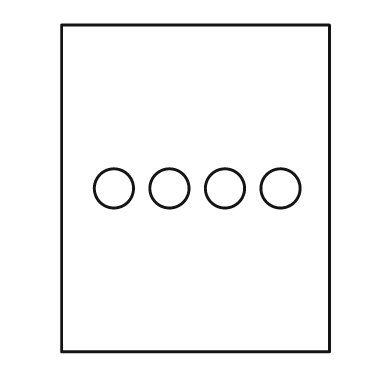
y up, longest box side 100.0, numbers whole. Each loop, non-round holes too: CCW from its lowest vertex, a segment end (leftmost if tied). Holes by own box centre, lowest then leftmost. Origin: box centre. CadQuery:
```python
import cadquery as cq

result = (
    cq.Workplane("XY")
    .moveTo(-41.0, -50.0)
    .lineTo(41.0, -50.0)
    .lineTo(41.0, 50.0)
    .lineTo(-41.0, 50.0)
    .close()
    .moveTo(-25.0, 0.0)
    .circle(6.0)
    .moveTo(-8.0, 0.0)
    .circle(6.0)
    .moveTo(9.0, 0.0)
    .circle(6.0)
    .moveTo(26.0, 0.0)
    .circle(6.0)
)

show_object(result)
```